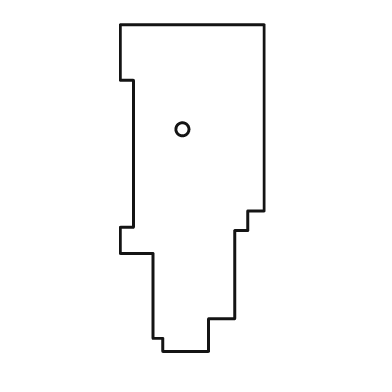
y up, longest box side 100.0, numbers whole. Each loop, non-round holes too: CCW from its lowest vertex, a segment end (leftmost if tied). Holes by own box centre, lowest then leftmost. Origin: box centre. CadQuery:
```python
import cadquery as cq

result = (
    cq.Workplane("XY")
    .moveTo(-9.0, -50.0)
    .lineTo(5.0, -50.0)
    .lineTo(5.0, -40.0)
    .lineTo(13.0, -40.0)
    .lineTo(13.0, -13.0)
    .lineTo(17.0, -13.0)
    .lineTo(17.0, -7.0)
    .lineTo(22.0, -7.0)
    .lineTo(22.0, 50.0)
    .lineTo(-22.0, 50.0)
    .lineTo(-22.0, 33.0)
    .lineTo(-18.0, 33.0)
    .lineTo(-18.0, -12.0)
    .lineTo(-22.0, -12.0)
    .lineTo(-22.0, -20.0)
    .lineTo(-12.0, -20.0)
    .lineTo(-12.0, -46.0)
    .lineTo(-9.0, -46.0)
    .close()
    .moveTo(-3.0, 18.0)
    .circle(2.0)
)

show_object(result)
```